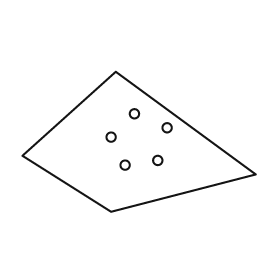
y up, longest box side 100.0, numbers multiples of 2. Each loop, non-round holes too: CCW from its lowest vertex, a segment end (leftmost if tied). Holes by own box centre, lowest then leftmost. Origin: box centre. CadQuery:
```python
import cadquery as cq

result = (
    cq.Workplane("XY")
    .moveTo(-12.0, -30.0)
    .lineTo(50.0, -14.0)
    .lineTo(-10.0, 30.0)
    .lineTo(-50.0, -6.0)
    .close()
    .moveTo(-6.0, -10.0)
    .circle(2.0)
    .moveTo(8.0, -8.0)
    .circle(2.0)
    .moveTo(-12.0, 2.0)
    .circle(2.0)
    .moveTo(12.0, 6.0)
    .circle(2.0)
    .moveTo(-2.0, 12.0)
    .circle(2.0)
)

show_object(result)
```